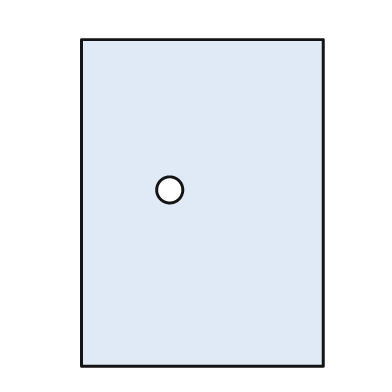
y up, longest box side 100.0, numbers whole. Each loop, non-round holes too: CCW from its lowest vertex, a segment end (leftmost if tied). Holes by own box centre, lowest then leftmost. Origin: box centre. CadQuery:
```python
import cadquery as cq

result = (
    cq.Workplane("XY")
    .moveTo(-37.0, -50.0)
    .lineTo(37.0, -50.0)
    .lineTo(37.0, 50.0)
    .lineTo(-37.0, 50.0)
    .close()
    .moveTo(-10.0, 4.0)
    .circle(4.0)
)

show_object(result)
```